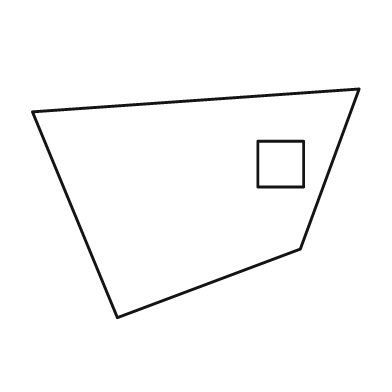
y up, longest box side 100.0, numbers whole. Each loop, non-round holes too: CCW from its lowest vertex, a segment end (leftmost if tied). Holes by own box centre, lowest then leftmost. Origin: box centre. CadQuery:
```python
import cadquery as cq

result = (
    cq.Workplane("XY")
    .moveTo(-24.0, -35.0)
    .lineTo(32.0, -14.0)
    .lineTo(50.0, 35.0)
    .lineTo(-50.0, 28.0)
    .close()
    .moveTo(19.0, 5.0)
    .lineTo(33.0, 5.0)
    .lineTo(33.0, 19.0)
    .lineTo(19.0, 19.0)
    .close()
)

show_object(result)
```